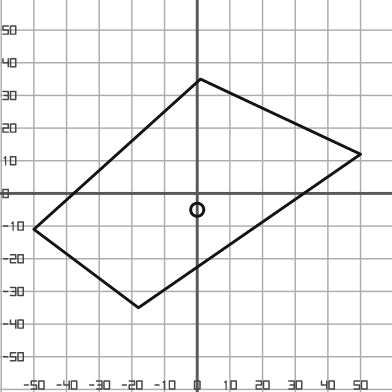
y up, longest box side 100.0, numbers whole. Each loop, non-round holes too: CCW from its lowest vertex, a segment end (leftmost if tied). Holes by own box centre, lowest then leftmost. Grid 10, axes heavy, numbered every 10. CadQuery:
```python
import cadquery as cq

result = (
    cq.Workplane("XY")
    .moveTo(-18.0, -35.0)
    .lineTo(50.0, 12.0)
    .lineTo(1.0, 35.0)
    .lineTo(-50.0, -11.0)
    .close()
    .moveTo(0.0, -5.0)
    .circle(2.0)
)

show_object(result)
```